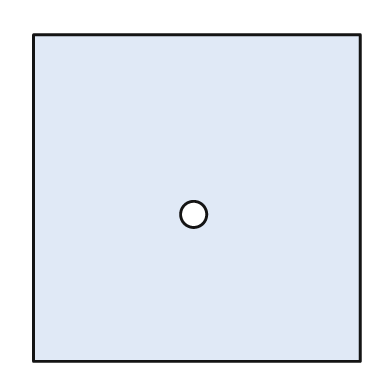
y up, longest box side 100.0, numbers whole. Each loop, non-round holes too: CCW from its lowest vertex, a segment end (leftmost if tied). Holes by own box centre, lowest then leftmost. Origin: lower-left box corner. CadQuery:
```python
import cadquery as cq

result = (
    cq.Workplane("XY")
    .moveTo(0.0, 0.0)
    .lineTo(100.0, 0.0)
    .lineTo(100.0, 100.0)
    .lineTo(0.0, 100.0)
    .close()
    .moveTo(49.0, 45.0)
    .circle(4.0)
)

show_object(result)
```